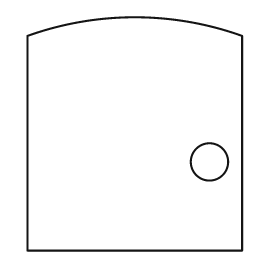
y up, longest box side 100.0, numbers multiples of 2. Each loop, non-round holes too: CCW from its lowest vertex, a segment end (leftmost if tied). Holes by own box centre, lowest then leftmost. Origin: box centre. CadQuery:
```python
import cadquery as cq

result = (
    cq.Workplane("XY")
    .moveTo(-46.0, -50.0)
    .lineTo(46.0, -50.0)
    .lineTo(46.0, 42.0)
    .threePointArc((0.0, 50.0), (-46.0, 42.0))
    .close()
    .moveTo(32.0, -12.0)
    .circle(8.0)
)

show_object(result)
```